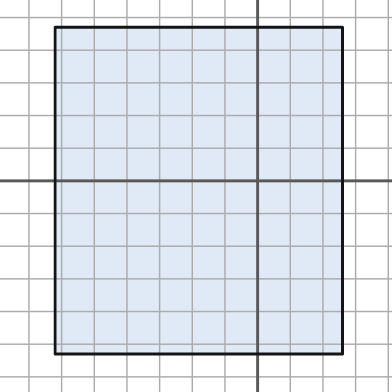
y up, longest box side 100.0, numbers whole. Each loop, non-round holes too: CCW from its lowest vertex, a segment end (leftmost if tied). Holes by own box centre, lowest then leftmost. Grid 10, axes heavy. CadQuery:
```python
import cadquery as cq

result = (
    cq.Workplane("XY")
    .moveTo(-62.0, -53.0)
    .lineTo(26.0, -53.0)
    .lineTo(26.0, 47.0)
    .lineTo(-62.0, 47.0)
    .close()
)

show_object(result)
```